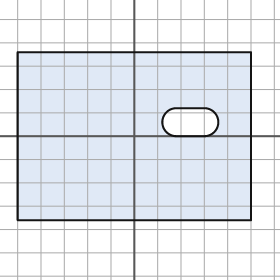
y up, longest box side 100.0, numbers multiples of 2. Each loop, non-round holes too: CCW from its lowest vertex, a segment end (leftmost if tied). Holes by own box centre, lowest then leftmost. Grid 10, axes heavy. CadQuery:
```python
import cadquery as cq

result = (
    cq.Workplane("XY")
    .moveTo(-50.0, -36.0)
    .lineTo(50.0, -36.0)
    .lineTo(50.0, 36.0)
    .lineTo(-50.0, 36.0)
    .close()
    .moveTo(18.0, 0.0)
    .lineTo(30.0, 0.0)
    .threePointArc((36.0, 6.0), (30.0, 12.0))
    .lineTo(18.0, 12.0)
    .threePointArc((12.0, 6.0), (18.0, 0.0))
    .close()
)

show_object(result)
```